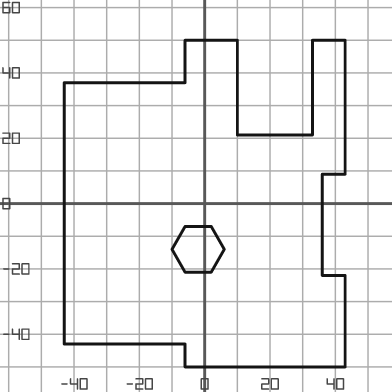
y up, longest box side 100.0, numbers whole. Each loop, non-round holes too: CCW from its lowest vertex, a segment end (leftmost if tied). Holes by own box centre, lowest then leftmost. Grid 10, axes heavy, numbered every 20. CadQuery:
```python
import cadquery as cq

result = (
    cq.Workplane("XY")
    .moveTo(-6.0, -50.0)
    .lineTo(43.0, -50.0)
    .lineTo(43.0, -22.0)
    .lineTo(36.0, -22.0)
    .lineTo(36.0, 9.0)
    .lineTo(43.0, 9.0)
    .lineTo(43.0, 50.0)
    .lineTo(33.0, 50.0)
    .lineTo(33.0, 21.0)
    .lineTo(10.0, 21.0)
    .lineTo(10.0, 50.0)
    .lineTo(-6.0, 50.0)
    .lineTo(-6.0, 37.0)
    .lineTo(-43.0, 37.0)
    .lineTo(-43.0, -43.0)
    .lineTo(-6.0, -43.0)
    .close()
    .moveTo(-6.0, -21.0)
    .lineTo(2.0, -21.0)
    .lineTo(6.0, -14.0)
    .lineTo(2.0, -7.0)
    .lineTo(-6.0, -7.0)
    .lineTo(-10.0, -14.0)
    .close()
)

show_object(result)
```